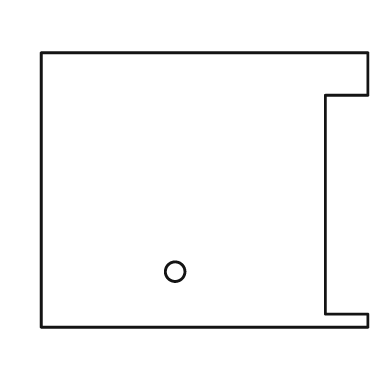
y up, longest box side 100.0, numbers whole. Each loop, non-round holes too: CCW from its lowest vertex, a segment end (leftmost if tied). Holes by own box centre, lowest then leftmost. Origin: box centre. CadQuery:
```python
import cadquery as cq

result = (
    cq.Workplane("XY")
    .moveTo(-50.0, -42.0)
    .lineTo(50.0, -42.0)
    .lineTo(50.0, -38.0)
    .lineTo(37.0, -38.0)
    .lineTo(37.0, 29.0)
    .lineTo(50.0, 29.0)
    .lineTo(50.0, 42.0)
    .lineTo(-50.0, 42.0)
    .close()
    .moveTo(-9.0, -25.0)
    .circle(3.0)
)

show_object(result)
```